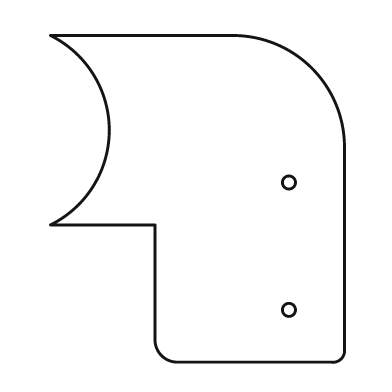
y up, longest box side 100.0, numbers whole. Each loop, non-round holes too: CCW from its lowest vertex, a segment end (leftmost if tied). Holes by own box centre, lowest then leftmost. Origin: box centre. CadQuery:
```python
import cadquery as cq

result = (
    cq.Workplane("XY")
    .moveTo(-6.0, -50.0)
    .lineTo(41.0, -50.0)
    .threePointArc((44.0, -49.0), (45.0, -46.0))
    .lineTo(45.0, 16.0)
    .threePointArc((35.0, 40.0), (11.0, 50.0))
    .lineTo(-45.0, 50.0)
    .threePointArc((-27.0, 21.0), (-45.0, -8.0))
    .lineTo(-13.0, -8.0)
    .lineTo(-13.0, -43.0)
    .threePointArc((-11.0, -48.0), (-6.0, -50.0))
    .close()
    .moveTo(28.0, -34.0)
    .circle(2.0)
    .moveTo(28.0, 5.0)
    .circle(2.0)
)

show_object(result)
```